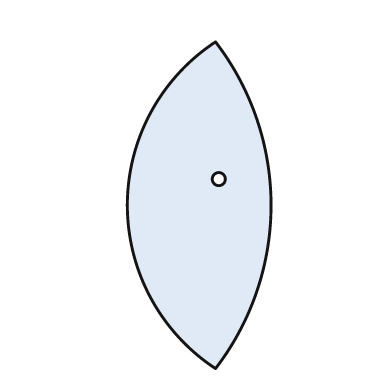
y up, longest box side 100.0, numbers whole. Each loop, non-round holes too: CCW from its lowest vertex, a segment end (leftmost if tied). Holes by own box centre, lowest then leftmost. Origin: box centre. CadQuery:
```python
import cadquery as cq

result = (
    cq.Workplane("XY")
    .moveTo(5.0, -50.0)
    .threePointArc((22.0, 0.0), (5.0, 50.0))
    .threePointArc((-22.0, 0.0), (5.0, -50.0))
    .close()
    .moveTo(6.0, 8.0)
    .circle(2.0)
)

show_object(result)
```